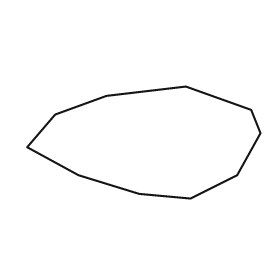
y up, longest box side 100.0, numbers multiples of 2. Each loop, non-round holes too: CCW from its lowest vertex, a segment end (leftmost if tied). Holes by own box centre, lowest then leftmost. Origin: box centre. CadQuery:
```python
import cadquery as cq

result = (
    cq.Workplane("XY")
    .moveTo(20.0, -24.0)
    .lineTo(40.0, -14.0)
    .lineTo(50.0, 4.0)
    .lineTo(46.0, 14.0)
    .lineTo(18.0, 24.0)
    .lineTo(-16.0, 20.0)
    .lineTo(-38.0, 12.0)
    .lineTo(-50.0, -2.0)
    .lineTo(-28.0, -14.0)
    .lineTo(-2.0, -22.0)
    .close()
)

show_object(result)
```